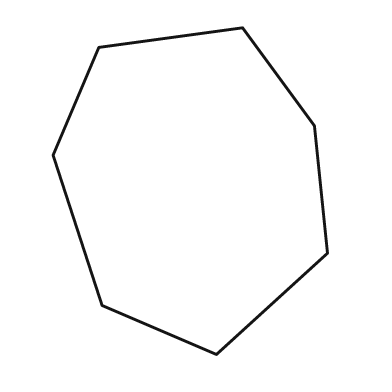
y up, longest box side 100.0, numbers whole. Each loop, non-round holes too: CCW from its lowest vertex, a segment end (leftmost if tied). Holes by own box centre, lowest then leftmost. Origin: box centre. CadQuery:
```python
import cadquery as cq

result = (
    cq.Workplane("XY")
    .moveTo(8.0, -50.0)
    .lineTo(42.0, -19.0)
    .lineTo(38.0, 20.0)
    .lineTo(16.0, 50.0)
    .lineTo(-28.0, 44.0)
    .lineTo(-42.0, 11.0)
    .lineTo(-27.0, -35.0)
    .close()
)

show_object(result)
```